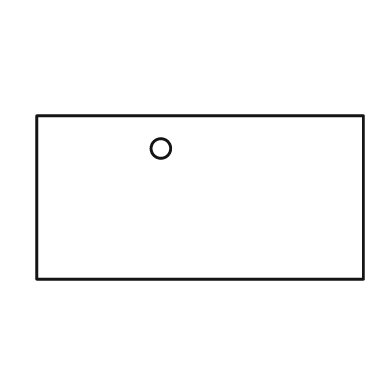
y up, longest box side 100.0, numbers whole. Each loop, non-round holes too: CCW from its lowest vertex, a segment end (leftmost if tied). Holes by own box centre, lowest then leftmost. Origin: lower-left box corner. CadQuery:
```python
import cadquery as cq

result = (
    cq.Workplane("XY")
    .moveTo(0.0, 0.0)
    .lineTo(100.0, 0.0)
    .lineTo(100.0, 50.0)
    .lineTo(0.0, 50.0)
    .close()
    .moveTo(38.0, 40.0)
    .circle(3.0)
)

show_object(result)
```